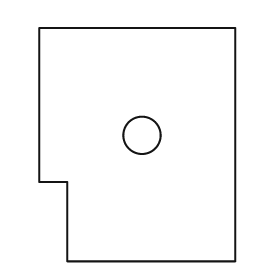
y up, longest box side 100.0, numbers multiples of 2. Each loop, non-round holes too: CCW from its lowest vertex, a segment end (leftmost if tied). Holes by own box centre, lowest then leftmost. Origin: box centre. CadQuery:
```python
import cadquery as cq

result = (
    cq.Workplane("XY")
    .moveTo(-30.0, -50.0)
    .lineTo(42.0, -50.0)
    .lineTo(42.0, 50.0)
    .lineTo(-42.0, 50.0)
    .lineTo(-42.0, -16.0)
    .lineTo(-30.0, -16.0)
    .close()
    .moveTo(2.0, 4.0)
    .circle(8.0)
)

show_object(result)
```